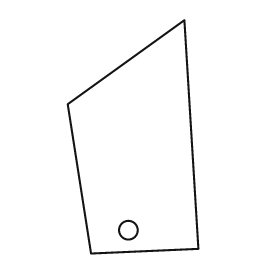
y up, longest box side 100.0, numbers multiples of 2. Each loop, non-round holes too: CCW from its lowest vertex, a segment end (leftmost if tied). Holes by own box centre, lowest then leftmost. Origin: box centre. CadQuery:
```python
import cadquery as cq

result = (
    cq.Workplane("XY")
    .moveTo(-18.0, -50.0)
    .lineTo(28.0, -48.0)
    .lineTo(22.0, 50.0)
    .lineTo(-28.0, 14.0)
    .close()
    .moveTo(-2.0, -40.0)
    .circle(4.0)
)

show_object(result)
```